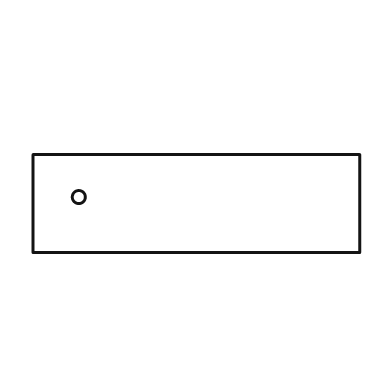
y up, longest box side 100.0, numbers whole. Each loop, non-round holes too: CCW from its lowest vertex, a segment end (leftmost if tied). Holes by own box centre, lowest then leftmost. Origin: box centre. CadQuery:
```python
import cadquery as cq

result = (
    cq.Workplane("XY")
    .moveTo(-50.0, -15.0)
    .lineTo(50.0, -15.0)
    .lineTo(50.0, 15.0)
    .lineTo(-50.0, 15.0)
    .close()
    .moveTo(-36.0, 2.0)
    .circle(2.0)
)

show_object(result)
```